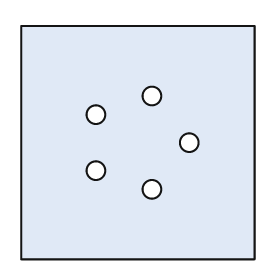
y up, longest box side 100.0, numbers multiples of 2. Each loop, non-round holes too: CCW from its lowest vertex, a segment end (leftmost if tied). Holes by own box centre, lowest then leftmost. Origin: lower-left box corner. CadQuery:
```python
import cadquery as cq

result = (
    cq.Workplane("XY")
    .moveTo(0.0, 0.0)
    .lineTo(100.0, 0.0)
    .lineTo(100.0, 100.0)
    .lineTo(0.0, 100.0)
    .close()
    .moveTo(56.0, 30.0)
    .circle(4.0)
    .moveTo(32.0, 38.0)
    .circle(4.0)
    .moveTo(72.0, 50.0)
    .circle(4.0)
    .moveTo(32.0, 62.0)
    .circle(4.0)
    .moveTo(56.0, 70.0)
    .circle(4.0)
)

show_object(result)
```